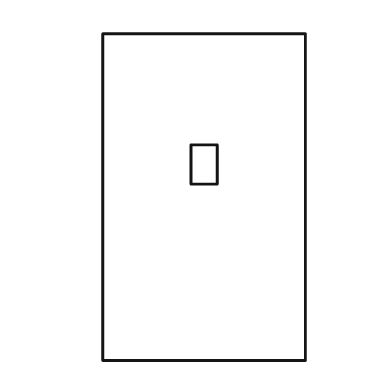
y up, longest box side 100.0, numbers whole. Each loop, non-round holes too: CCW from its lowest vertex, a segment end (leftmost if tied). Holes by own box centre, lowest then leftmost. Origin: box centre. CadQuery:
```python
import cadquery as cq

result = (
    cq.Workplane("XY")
    .moveTo(-31.0, -50.0)
    .lineTo(31.0, -50.0)
    .lineTo(31.0, 50.0)
    .lineTo(-31.0, 50.0)
    .close()
    .moveTo(-4.0, 4.0)
    .lineTo(4.0, 4.0)
    .lineTo(4.0, 16.0)
    .lineTo(-4.0, 16.0)
    .close()
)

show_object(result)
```